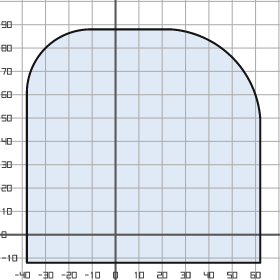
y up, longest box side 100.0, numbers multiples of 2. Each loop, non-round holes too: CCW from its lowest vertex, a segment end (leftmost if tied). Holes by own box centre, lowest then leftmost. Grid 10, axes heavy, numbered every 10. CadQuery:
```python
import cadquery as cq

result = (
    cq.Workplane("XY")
    .moveTo(-38.0, -12.0)
    .lineTo(62.0, -12.0)
    .lineTo(62.0, 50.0)
    .threePointArc((50.0, 76.0), (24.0, 88.0))
    .lineTo(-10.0, 88.0)
    .threePointArc((-30.0, 80.0), (-38.0, 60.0))
    .close()
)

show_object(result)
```